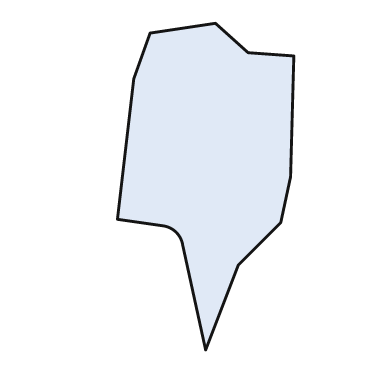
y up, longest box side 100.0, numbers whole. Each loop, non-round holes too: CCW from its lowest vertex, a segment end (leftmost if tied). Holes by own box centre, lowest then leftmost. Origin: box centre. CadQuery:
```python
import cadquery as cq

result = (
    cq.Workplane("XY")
    .moveTo(0.0, -50.0)
    .lineTo(10.0, -24.0)
    .lineTo(23.0, -11.0)
    .lineTo(26.0, 3.0)
    .lineTo(27.0, 40.0)
    .lineTo(13.0, 41.0)
    .lineTo(3.0, 50.0)
    .lineTo(-17.0, 47.0)
    .lineTo(-22.0, 33.0)
    .lineTo(-27.0, -10.0)
    .lineTo(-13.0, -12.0)
    .threePointArc((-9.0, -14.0), (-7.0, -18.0))
    .close()
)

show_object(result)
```